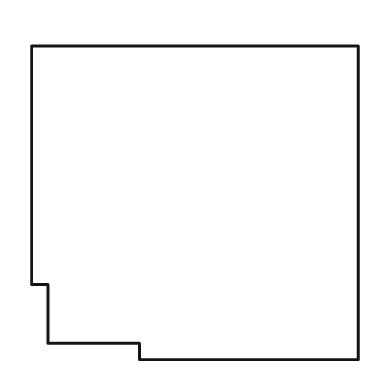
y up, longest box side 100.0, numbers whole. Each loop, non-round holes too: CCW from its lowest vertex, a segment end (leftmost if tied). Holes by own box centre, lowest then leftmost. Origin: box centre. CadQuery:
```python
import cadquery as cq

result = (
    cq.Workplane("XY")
    .moveTo(-17.0, -48.0)
    .lineTo(50.0, -48.0)
    .lineTo(50.0, 48.0)
    .lineTo(-50.0, 48.0)
    .lineTo(-50.0, -25.0)
    .lineTo(-45.0, -25.0)
    .lineTo(-45.0, -43.0)
    .lineTo(-17.0, -43.0)
    .close()
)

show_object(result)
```